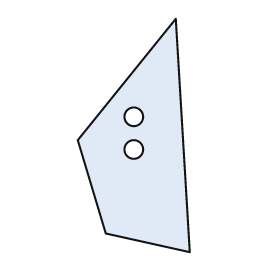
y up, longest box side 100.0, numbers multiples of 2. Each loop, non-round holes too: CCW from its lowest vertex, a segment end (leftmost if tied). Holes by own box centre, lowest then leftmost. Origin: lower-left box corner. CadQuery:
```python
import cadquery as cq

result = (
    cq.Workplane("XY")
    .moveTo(48.0, 0.0)
    .lineTo(42.0, 100.0)
    .lineTo(0.0, 48.0)
    .lineTo(12.0, 8.0)
    .close()
    .moveTo(24.0, 44.0)
    .circle(4.0)
    .moveTo(24.0, 58.0)
    .circle(4.0)
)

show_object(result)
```